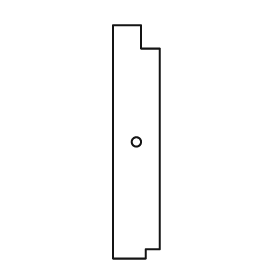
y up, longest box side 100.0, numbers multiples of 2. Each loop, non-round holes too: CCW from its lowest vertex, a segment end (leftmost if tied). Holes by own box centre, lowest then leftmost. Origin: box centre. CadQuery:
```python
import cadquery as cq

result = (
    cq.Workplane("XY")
    .moveTo(-10.0, -50.0)
    .lineTo(4.0, -50.0)
    .lineTo(4.0, -46.0)
    .lineTo(10.0, -46.0)
    .lineTo(10.0, 40.0)
    .lineTo(2.0, 40.0)
    .lineTo(2.0, 50.0)
    .lineTo(-10.0, 50.0)
    .close()
    .moveTo(0.0, 0.0)
    .circle(2.0)
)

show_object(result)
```